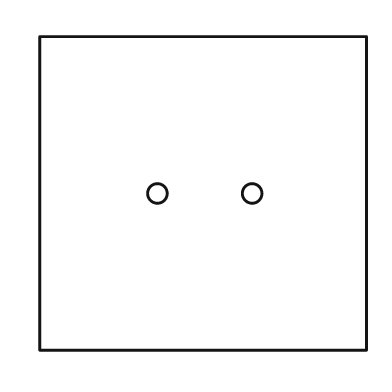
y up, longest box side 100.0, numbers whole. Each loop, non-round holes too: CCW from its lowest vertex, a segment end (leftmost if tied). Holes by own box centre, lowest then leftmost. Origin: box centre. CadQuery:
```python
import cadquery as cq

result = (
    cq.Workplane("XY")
    .moveTo(-50.0, -48.0)
    .lineTo(50.0, -48.0)
    .lineTo(50.0, 48.0)
    .lineTo(-50.0, 48.0)
    .close()
    .moveTo(-14.0, 0.0)
    .circle(3.0)
    .moveTo(15.0, 0.0)
    .circle(3.0)
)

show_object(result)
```